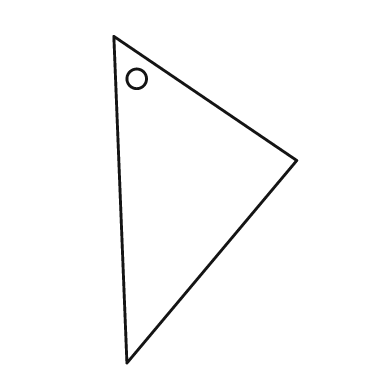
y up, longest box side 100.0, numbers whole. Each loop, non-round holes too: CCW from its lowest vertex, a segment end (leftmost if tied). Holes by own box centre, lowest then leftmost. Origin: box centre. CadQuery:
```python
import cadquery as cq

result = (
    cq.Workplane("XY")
    .moveTo(-24.0, -50.0)
    .lineTo(28.0, 12.0)
    .lineTo(-28.0, 50.0)
    .close()
    .moveTo(-21.0, 37.0)
    .circle(3.0)
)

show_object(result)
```